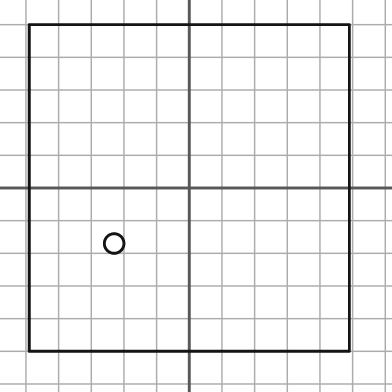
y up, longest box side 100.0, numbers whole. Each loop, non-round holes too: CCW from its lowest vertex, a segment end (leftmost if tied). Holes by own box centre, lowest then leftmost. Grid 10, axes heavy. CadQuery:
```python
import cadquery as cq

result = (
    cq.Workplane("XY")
    .moveTo(-49.0, -50.0)
    .lineTo(49.0, -50.0)
    .lineTo(49.0, 50.0)
    .lineTo(-49.0, 50.0)
    .close()
    .moveTo(-23.0, -17.0)
    .circle(3.0)
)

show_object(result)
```